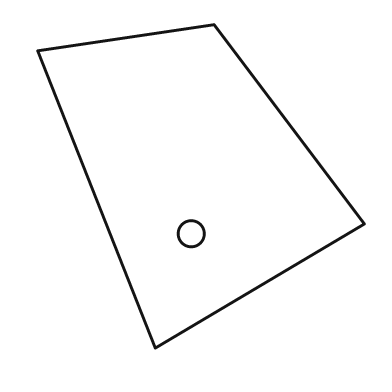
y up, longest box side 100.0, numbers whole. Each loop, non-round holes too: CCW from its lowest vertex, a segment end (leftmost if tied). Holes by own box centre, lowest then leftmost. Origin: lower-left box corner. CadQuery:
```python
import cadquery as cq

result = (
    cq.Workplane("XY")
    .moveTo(36.0, 0.0)
    .lineTo(100.0, 38.0)
    .lineTo(54.0, 99.0)
    .lineTo(0.0, 91.0)
    .close()
    .moveTo(47.0, 35.0)
    .circle(4.0)
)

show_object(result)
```